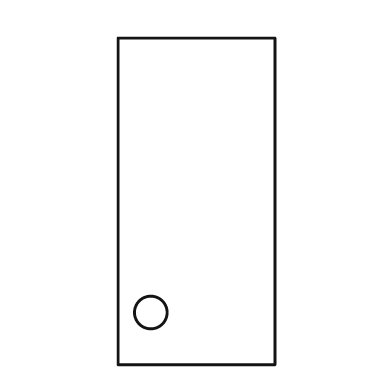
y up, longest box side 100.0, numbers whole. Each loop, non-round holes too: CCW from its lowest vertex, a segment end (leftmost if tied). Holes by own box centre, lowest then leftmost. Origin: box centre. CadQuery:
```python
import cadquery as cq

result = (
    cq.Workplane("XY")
    .moveTo(-24.0, -50.0)
    .lineTo(24.0, -50.0)
    .lineTo(24.0, 50.0)
    .lineTo(-24.0, 50.0)
    .close()
    .moveTo(-14.0, -34.0)
    .circle(5.0)
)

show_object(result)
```